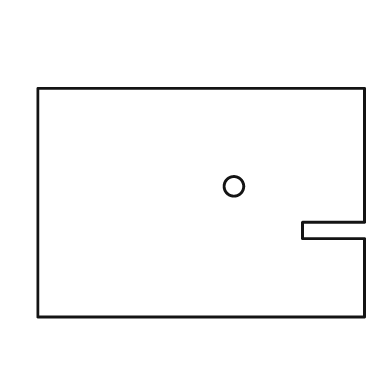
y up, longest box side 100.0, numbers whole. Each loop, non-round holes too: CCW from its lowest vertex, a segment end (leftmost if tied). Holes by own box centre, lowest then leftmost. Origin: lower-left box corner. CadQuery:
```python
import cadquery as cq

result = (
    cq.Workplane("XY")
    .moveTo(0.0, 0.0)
    .lineTo(100.0, 0.0)
    .lineTo(100.0, 24.0)
    .lineTo(81.0, 24.0)
    .lineTo(81.0, 29.0)
    .lineTo(100.0, 29.0)
    .lineTo(100.0, 70.0)
    .lineTo(0.0, 70.0)
    .close()
    .moveTo(60.0, 40.0)
    .circle(3.0)
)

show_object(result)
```